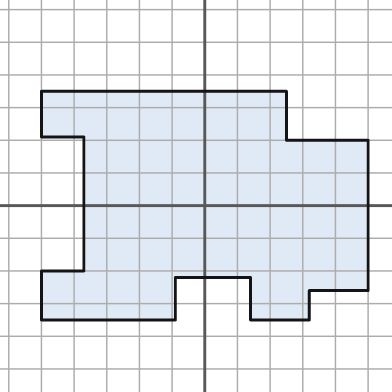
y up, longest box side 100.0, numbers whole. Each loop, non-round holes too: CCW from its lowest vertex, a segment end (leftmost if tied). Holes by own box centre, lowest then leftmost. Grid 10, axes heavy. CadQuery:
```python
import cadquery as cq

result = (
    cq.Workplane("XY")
    .moveTo(-50.0, -35.0)
    .lineTo(-9.0, -35.0)
    .lineTo(-9.0, -22.0)
    .lineTo(14.0, -22.0)
    .lineTo(14.0, -35.0)
    .lineTo(32.0, -35.0)
    .lineTo(32.0, -26.0)
    .lineTo(50.0, -26.0)
    .lineTo(50.0, 20.0)
    .lineTo(25.0, 20.0)
    .lineTo(25.0, 35.0)
    .lineTo(-50.0, 35.0)
    .lineTo(-50.0, 21.0)
    .lineTo(-37.0, 21.0)
    .lineTo(-37.0, -20.0)
    .lineTo(-50.0, -20.0)
    .close()
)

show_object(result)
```